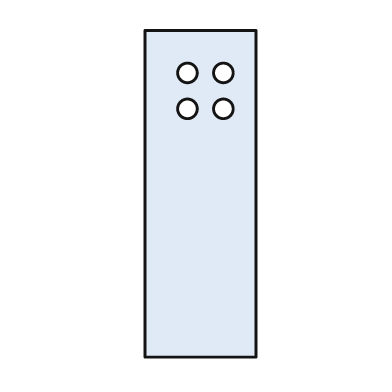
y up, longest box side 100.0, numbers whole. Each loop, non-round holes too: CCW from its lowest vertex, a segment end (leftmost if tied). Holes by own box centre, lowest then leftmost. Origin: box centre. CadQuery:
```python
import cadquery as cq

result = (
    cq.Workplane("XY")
    .moveTo(-17.0, -50.0)
    .lineTo(17.0, -50.0)
    .lineTo(17.0, 50.0)
    .lineTo(-17.0, 50.0)
    .close()
    .moveTo(-4.0, 26.0)
    .circle(3.0)
    .moveTo(7.0, 26.0)
    .circle(3.0)
    .moveTo(-4.0, 37.0)
    .circle(3.0)
    .moveTo(7.0, 37.0)
    .circle(3.0)
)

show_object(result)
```